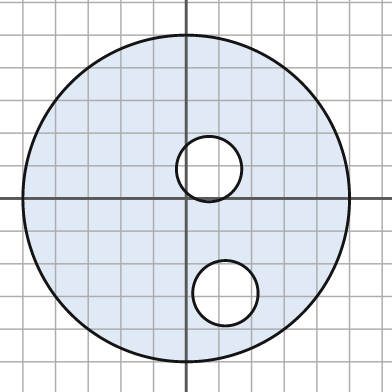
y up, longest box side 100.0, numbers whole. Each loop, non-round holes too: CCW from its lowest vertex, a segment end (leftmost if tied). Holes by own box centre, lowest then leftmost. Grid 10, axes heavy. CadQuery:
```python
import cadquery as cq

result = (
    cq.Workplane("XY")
    .moveTo(0.0, 0.0)
    .circle(50.0)
    .moveTo(12.0, -29.0)
    .circle(10.0)
    .moveTo(7.0, 9.0)
    .circle(10.0)
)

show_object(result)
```